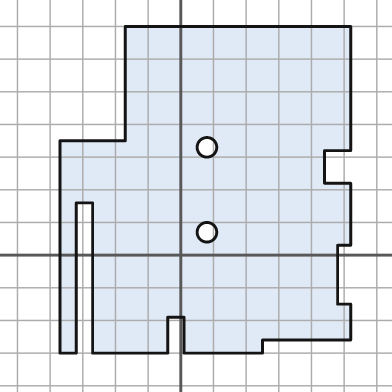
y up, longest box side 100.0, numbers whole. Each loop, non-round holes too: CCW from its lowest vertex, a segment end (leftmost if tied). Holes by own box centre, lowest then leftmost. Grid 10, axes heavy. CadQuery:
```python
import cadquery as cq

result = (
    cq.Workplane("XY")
    .moveTo(-37.0, -30.0)
    .lineTo(-32.0, -30.0)
    .lineTo(-32.0, 16.0)
    .lineTo(-27.0, 16.0)
    .lineTo(-27.0, -30.0)
    .lineTo(-4.0, -30.0)
    .lineTo(-4.0, -19.0)
    .lineTo(1.0, -19.0)
    .lineTo(1.0, -30.0)
    .lineTo(25.0, -30.0)
    .lineTo(25.0, -26.0)
    .lineTo(52.0, -26.0)
    .lineTo(52.0, -15.0)
    .lineTo(48.0, -15.0)
    .lineTo(48.0, 3.0)
    .lineTo(52.0, 3.0)
    .lineTo(52.0, 22.0)
    .lineTo(44.0, 22.0)
    .lineTo(44.0, 32.0)
    .lineTo(52.0, 32.0)
    .lineTo(52.0, 70.0)
    .lineTo(-17.0, 70.0)
    .lineTo(-17.0, 35.0)
    .lineTo(-37.0, 35.0)
    .close()
    .moveTo(8.0, 7.0)
    .circle(3.0)
    .moveTo(8.0, 33.0)
    .circle(3.0)
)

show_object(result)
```